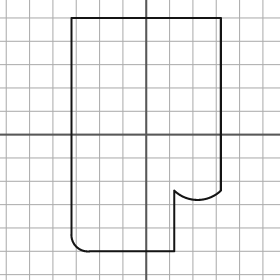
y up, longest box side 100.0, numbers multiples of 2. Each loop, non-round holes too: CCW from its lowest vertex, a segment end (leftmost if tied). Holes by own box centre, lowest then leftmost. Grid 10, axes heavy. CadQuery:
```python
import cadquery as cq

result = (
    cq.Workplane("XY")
    .moveTo(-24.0, -50.0)
    .lineTo(12.0, -50.0)
    .lineTo(12.0, -24.0)
    .threePointArc((22.0, -28.0), (32.0, -24.0))
    .lineTo(32.0, 50.0)
    .lineTo(-32.0, 50.0)
    .lineTo(-32.0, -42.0)
    .threePointArc((-30.0, -48.0), (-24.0, -50.0))
    .close()
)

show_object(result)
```